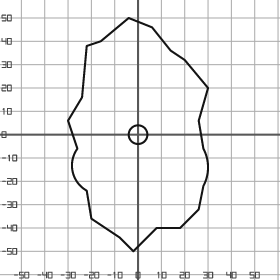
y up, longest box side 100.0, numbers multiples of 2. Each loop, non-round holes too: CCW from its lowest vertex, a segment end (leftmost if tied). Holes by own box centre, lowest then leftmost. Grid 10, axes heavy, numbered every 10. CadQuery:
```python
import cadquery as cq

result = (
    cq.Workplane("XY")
    .moveTo(-2.0, -50.0)
    .lineTo(8.0, -40.0)
    .lineTo(18.0, -40.0)
    .lineTo(26.0, -32.0)
    .lineTo(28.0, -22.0)
    .threePointArc((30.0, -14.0), (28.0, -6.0))
    .lineTo(26.0, 6.0)
    .lineTo(30.0, 20.0)
    .lineTo(20.0, 32.0)
    .lineTo(14.0, 36.0)
    .lineTo(6.0, 46.0)
    .lineTo(-4.0, 50.0)
    .lineTo(-16.0, 40.0)
    .lineTo(-22.0, 38.0)
    .lineTo(-24.0, 16.0)
    .lineTo(-30.0, 6.0)
    .lineTo(-26.0, -6.0)
    .threePointArc((-28.0, -16.0), (-22.0, -24.0))
    .lineTo(-20.0, -36.0)
    .lineTo(-8.0, -44.0)
    .close()
    .moveTo(0.0, 0.0)
    .circle(4.0)
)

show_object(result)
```